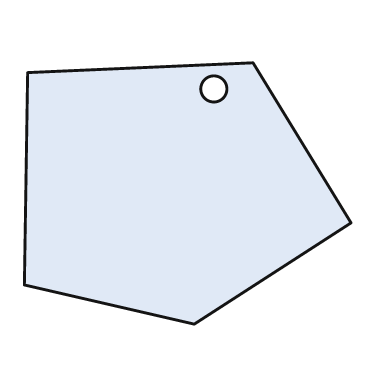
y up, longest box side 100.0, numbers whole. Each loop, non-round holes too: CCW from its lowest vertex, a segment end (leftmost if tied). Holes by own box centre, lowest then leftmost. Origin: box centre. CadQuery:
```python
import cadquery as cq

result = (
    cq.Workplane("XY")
    .moveTo(2.0, -40.0)
    .lineTo(50.0, -9.0)
    .lineTo(20.0, 40.0)
    .lineTo(-49.0, 37.0)
    .lineTo(-50.0, -28.0)
    .close()
    .moveTo(8.0, 32.0)
    .circle(4.0)
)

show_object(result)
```